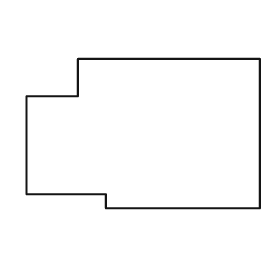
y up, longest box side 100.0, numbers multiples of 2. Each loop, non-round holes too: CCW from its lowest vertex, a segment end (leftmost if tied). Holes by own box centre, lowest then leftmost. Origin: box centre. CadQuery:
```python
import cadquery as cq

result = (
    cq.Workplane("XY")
    .moveTo(-16.0, -32.0)
    .lineTo(50.0, -32.0)
    .lineTo(50.0, 32.0)
    .lineTo(-28.0, 32.0)
    .lineTo(-28.0, 16.0)
    .lineTo(-50.0, 16.0)
    .lineTo(-50.0, -26.0)
    .lineTo(-16.0, -26.0)
    .close()
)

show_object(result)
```